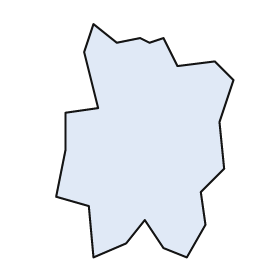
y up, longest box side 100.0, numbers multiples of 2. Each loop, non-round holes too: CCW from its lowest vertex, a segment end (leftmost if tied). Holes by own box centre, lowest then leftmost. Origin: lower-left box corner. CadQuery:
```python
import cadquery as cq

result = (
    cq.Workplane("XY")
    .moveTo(16.0, 0.0)
    .lineTo(30.0, 6.0)
    .lineTo(38.0, 16.0)
    .lineTo(46.0, 4.0)
    .lineTo(56.0, 0.0)
    .lineTo(64.0, 14.0)
    .lineTo(62.0, 28.0)
    .lineTo(72.0, 38.0)
    .lineTo(70.0, 58.0)
    .lineTo(76.0, 76.0)
    .lineTo(68.0, 84.0)
    .lineTo(52.0, 82.0)
    .lineTo(46.0, 94.0)
    .lineTo(40.0, 92.0)
    .lineTo(36.0, 94.0)
    .lineTo(26.0, 92.0)
    .lineTo(16.0, 100.0)
    .lineTo(12.0, 88.0)
    .lineTo(18.0, 64.0)
    .lineTo(4.0, 62.0)
    .lineTo(4.0, 46.0)
    .lineTo(0.0, 26.0)
    .lineTo(14.0, 22.0)
    .close()
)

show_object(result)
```